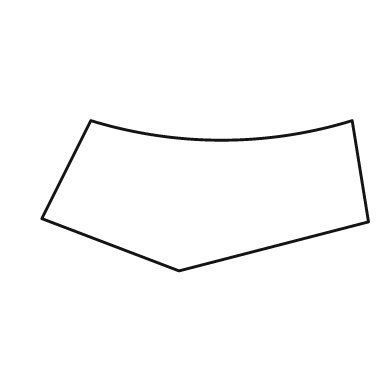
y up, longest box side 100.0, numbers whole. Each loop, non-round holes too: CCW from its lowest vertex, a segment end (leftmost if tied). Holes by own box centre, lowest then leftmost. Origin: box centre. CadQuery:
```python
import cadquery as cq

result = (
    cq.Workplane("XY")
    .moveTo(-8.0, -23.0)
    .lineTo(50.0, -8.0)
    .lineTo(45.0, 23.0)
    .threePointArc((5.0, 17.0), (-35.0, 23.0))
    .lineTo(-50.0, -7.0)
    .close()
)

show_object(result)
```